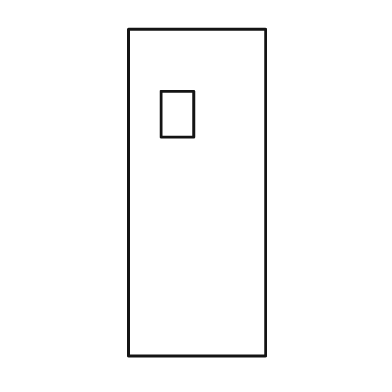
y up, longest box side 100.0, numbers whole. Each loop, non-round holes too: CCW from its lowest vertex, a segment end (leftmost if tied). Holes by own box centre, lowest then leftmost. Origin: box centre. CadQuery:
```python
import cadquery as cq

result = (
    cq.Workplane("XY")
    .moveTo(-21.0, -50.0)
    .lineTo(21.0, -50.0)
    .lineTo(21.0, 50.0)
    .lineTo(-21.0, 50.0)
    .close()
    .moveTo(-11.0, 17.0)
    .lineTo(-1.0, 17.0)
    .lineTo(-1.0, 31.0)
    .lineTo(-11.0, 31.0)
    .close()
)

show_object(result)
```